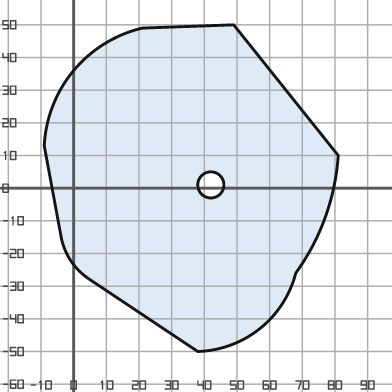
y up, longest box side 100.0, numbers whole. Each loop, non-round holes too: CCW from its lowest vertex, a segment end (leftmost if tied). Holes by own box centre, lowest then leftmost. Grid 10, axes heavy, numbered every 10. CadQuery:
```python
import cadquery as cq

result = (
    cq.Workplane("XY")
    .moveTo(38.0, -50.0)
    .threePointArc((57.0, -43.0), (68.0, -26.0))
    .threePointArc((77.0, -9.0), (81.0, 10.0))
    .lineTo(49.0, 50.0)
    .lineTo(21.0, 49.0)
    .threePointArc((0.0, 36.0), (-9.0, 13.0))
    .lineTo(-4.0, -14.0)
    .threePointArc((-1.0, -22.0), (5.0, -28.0))
    .close()
    .moveTo(42.0, 1.0)
    .circle(4.0)
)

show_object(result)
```